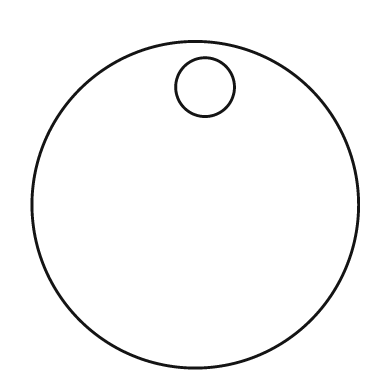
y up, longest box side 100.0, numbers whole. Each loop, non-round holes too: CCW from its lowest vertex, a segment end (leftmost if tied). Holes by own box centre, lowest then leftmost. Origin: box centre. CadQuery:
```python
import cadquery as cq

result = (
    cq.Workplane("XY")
    .moveTo(0.0, 0.0)
    .circle(50.0)
    .moveTo(3.0, 36.0)
    .circle(9.0)
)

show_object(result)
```